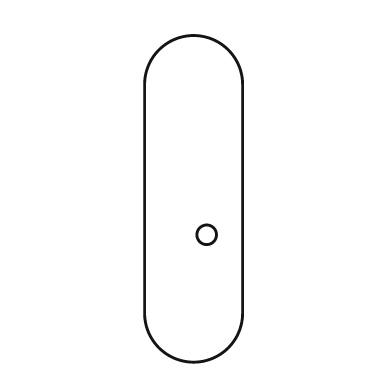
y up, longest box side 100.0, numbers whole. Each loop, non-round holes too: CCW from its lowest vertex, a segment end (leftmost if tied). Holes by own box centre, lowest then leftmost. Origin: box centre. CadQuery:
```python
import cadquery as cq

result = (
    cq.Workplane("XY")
    .moveTo(-15.0, -35.0)
    .threePointArc((0.0, -50.0), (15.0, -35.0))
    .lineTo(15.0, 35.0)
    .threePointArc((0.0, 50.0), (-15.0, 35.0))
    .close()
    .moveTo(4.0, -11.0)
    .circle(3.0)
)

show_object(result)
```